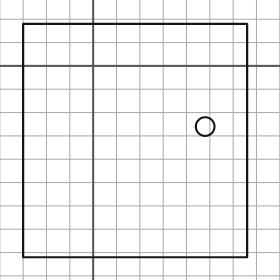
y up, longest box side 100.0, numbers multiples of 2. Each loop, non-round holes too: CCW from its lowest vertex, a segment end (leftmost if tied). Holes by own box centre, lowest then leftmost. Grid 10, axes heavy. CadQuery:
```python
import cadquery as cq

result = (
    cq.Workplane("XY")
    .moveTo(-30.0, -82.0)
    .lineTo(66.0, -82.0)
    .lineTo(66.0, 18.0)
    .lineTo(-30.0, 18.0)
    .close()
    .moveTo(48.0, -26.0)
    .circle(4.0)
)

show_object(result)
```